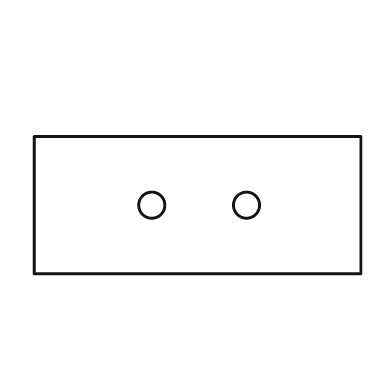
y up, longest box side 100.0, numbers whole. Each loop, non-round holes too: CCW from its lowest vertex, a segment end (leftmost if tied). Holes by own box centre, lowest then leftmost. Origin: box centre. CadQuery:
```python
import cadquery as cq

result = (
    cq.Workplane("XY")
    .moveTo(-50.0, -21.0)
    .lineTo(50.0, -21.0)
    .lineTo(50.0, 21.0)
    .lineTo(-50.0, 21.0)
    .close()
    .moveTo(-14.0, 0.0)
    .circle(4.0)
    .moveTo(15.0, 0.0)
    .circle(4.0)
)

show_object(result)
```